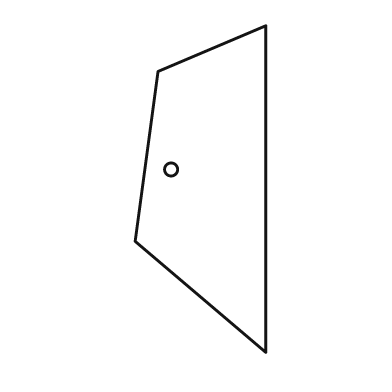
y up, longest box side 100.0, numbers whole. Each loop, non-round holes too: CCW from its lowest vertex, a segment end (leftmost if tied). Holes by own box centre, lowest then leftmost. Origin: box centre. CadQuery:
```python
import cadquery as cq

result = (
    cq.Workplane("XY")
    .moveTo(20.0, -50.0)
    .lineTo(20.0, 50.0)
    .lineTo(-13.0, 36.0)
    .lineTo(-20.0, -16.0)
    .close()
    .moveTo(-9.0, 6.0)
    .circle(2.0)
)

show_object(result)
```